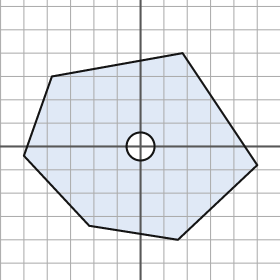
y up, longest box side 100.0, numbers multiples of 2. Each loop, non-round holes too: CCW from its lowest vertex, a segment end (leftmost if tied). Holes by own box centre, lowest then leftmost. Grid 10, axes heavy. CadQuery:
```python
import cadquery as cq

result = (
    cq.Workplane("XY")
    .moveTo(16.0, -40.0)
    .lineTo(50.0, -8.0)
    .lineTo(18.0, 40.0)
    .lineTo(-38.0, 30.0)
    .lineTo(-50.0, -4.0)
    .lineTo(-22.0, -34.0)
    .close()
    .moveTo(0.0, 0.0)
    .circle(6.0)
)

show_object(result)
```